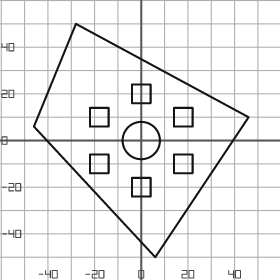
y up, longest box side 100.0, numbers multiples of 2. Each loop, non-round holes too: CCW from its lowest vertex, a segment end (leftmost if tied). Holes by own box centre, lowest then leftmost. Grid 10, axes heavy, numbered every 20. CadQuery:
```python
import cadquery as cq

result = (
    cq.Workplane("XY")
    .moveTo(6.0, -50.0)
    .lineTo(46.0, 10.0)
    .lineTo(-28.0, 50.0)
    .lineTo(-46.0, 6.0)
    .close()
    .moveTo(-4.0, -24.0)
    .lineTo(4.0, -24.0)
    .lineTo(4.0, -16.0)
    .lineTo(-4.0, -16.0)
    .close()
    .moveTo(-22.0, -14.0)
    .lineTo(-14.0, -14.0)
    .lineTo(-14.0, -6.0)
    .lineTo(-22.0, -6.0)
    .close()
    .moveTo(14.0, -14.0)
    .lineTo(22.0, -14.0)
    .lineTo(22.0, -6.0)
    .lineTo(14.0, -6.0)
    .close()
    .moveTo(0.0, 0.0)
    .circle(8.0)
    .moveTo(-22.0, 6.0)
    .lineTo(-14.0, 6.0)
    .lineTo(-14.0, 14.0)
    .lineTo(-22.0, 14.0)
    .close()
    .moveTo(14.0, 6.0)
    .lineTo(22.0, 6.0)
    .lineTo(22.0, 14.0)
    .lineTo(14.0, 14.0)
    .close()
    .moveTo(-4.0, 16.0)
    .lineTo(4.0, 16.0)
    .lineTo(4.0, 24.0)
    .lineTo(-4.0, 24.0)
    .close()
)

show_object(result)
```